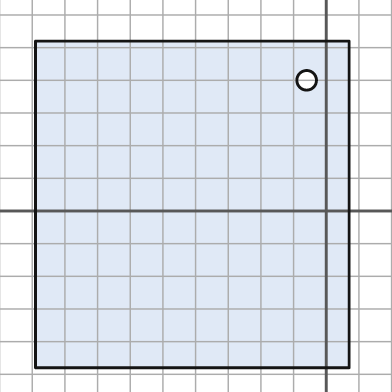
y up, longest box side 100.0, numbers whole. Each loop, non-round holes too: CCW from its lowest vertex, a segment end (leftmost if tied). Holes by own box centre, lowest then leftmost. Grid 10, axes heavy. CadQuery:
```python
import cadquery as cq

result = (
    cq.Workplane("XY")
    .moveTo(-89.0, -48.0)
    .lineTo(7.0, -48.0)
    .lineTo(7.0, 52.0)
    .lineTo(-89.0, 52.0)
    .close()
    .moveTo(-6.0, 40.0)
    .circle(3.0)
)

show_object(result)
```